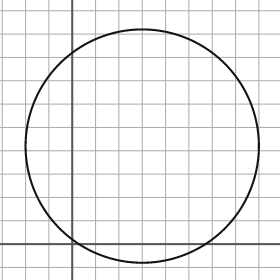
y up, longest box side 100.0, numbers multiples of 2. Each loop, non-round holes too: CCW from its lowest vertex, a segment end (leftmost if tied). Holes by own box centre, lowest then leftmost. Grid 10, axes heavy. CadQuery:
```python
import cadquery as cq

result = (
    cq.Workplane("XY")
    .moveTo(30.0, 42.0)
    .circle(50.0)
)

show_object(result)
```